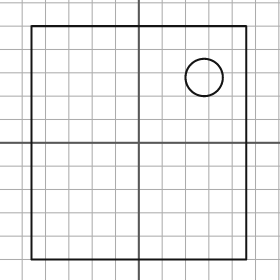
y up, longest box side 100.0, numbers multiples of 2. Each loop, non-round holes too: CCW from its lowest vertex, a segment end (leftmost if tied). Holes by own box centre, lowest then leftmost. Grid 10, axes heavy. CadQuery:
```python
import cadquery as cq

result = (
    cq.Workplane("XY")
    .moveTo(-46.0, -50.0)
    .lineTo(46.0, -50.0)
    .lineTo(46.0, 50.0)
    .lineTo(-46.0, 50.0)
    .close()
    .moveTo(28.0, 28.0)
    .circle(8.0)
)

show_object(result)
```